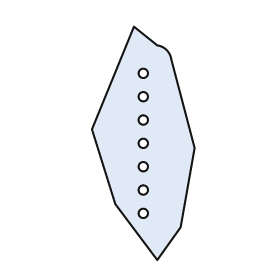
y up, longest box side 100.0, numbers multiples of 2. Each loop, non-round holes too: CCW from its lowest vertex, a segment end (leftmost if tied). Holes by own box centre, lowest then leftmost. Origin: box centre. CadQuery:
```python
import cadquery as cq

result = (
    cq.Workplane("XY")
    .moveTo(6.0, -50.0)
    .lineTo(16.0, -36.0)
    .lineTo(22.0, -2.0)
    .lineTo(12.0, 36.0)
    .threePointArc((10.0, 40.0), (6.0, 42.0))
    .lineTo(-4.0, 50.0)
    .lineTo(-22.0, 6.0)
    .lineTo(-12.0, -26.0)
    .close()
    .moveTo(0.0, -30.0)
    .circle(2.0)
    .moveTo(0.0, -20.0)
    .circle(2.0)
    .moveTo(0.0, -10.0)
    .circle(2.0)
    .moveTo(0.0, 0.0)
    .circle(2.0)
    .moveTo(0.0, 10.0)
    .circle(2.0)
    .moveTo(0.0, 20.0)
    .circle(2.0)
    .moveTo(0.0, 30.0)
    .circle(2.0)
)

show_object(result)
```